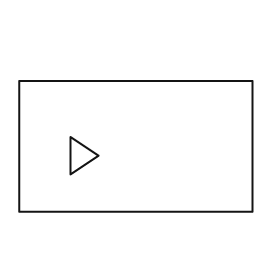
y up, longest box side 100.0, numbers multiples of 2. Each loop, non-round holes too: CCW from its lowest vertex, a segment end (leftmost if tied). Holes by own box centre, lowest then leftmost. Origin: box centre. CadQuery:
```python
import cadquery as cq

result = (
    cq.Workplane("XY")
    .moveTo(-50.0, -28.0)
    .lineTo(50.0, -28.0)
    .lineTo(50.0, 28.0)
    .lineTo(-50.0, 28.0)
    .close()
    .moveTo(-28.0, -12.0)
    .lineTo(-16.0, -4.0)
    .lineTo(-28.0, 4.0)
    .close()
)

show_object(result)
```